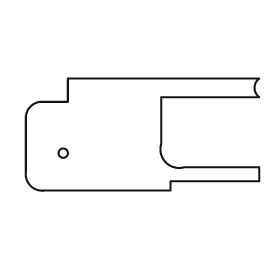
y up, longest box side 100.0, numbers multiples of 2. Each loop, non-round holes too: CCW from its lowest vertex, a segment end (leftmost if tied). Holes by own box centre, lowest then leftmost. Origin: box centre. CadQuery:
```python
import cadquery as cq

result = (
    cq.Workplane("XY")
    .moveTo(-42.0, -24.0)
    .lineTo(12.0, -24.0)
    .lineTo(12.0, -20.0)
    .lineTo(50.0, -20.0)
    .lineTo(50.0, -14.0)
    .lineTo(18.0, -14.0)
    .threePointArc((10.0, -12.0), (8.0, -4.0))
    .lineTo(8.0, 16.0)
    .lineTo(50.0, 16.0)
    .threePointArc((48.0, 20.0), (50.0, 24.0))
    .lineTo(-32.0, 24.0)
    .lineTo(-32.0, 14.0)
    .lineTo(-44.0, 14.0)
    .threePointArc((-48.0, 12.0), (-50.0, 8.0))
    .lineTo(-50.0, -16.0)
    .threePointArc((-48.0, -22.0), (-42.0, -24.0))
    .close()
    .moveTo(-34.0, -8.0)
    .circle(2.0)
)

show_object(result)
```